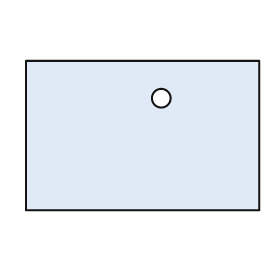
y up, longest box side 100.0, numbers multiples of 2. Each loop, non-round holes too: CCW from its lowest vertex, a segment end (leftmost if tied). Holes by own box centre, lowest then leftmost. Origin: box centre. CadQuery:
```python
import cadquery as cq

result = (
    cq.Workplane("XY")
    .moveTo(-50.0, -32.0)
    .lineTo(50.0, -32.0)
    .lineTo(50.0, 32.0)
    .lineTo(-50.0, 32.0)
    .close()
    .moveTo(8.0, 16.0)
    .circle(4.0)
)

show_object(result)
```